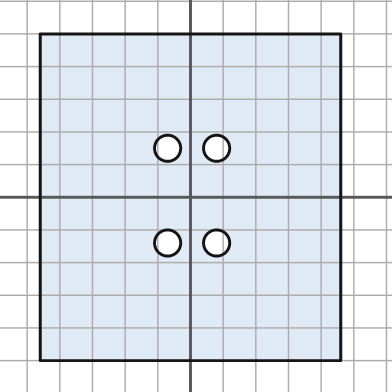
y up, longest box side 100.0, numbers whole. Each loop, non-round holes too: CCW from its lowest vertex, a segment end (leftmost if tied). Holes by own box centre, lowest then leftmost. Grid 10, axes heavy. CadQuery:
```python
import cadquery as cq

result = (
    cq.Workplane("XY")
    .moveTo(-46.0, -50.0)
    .lineTo(46.0, -50.0)
    .lineTo(46.0, 50.0)
    .lineTo(-46.0, 50.0)
    .close()
    .moveTo(-7.0, -14.0)
    .circle(4.0)
    .moveTo(8.0, -14.0)
    .circle(4.0)
    .moveTo(-7.0, 15.0)
    .circle(4.0)
    .moveTo(8.0, 15.0)
    .circle(4.0)
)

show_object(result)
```